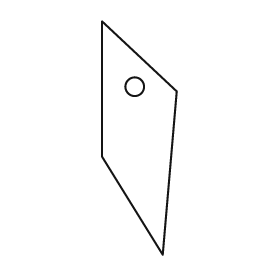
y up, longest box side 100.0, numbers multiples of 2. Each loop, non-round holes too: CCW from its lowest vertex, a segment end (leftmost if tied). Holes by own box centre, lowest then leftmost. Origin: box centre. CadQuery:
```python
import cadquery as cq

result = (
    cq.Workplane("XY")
    .moveTo(10.0, -50.0)
    .lineTo(16.0, 20.0)
    .lineTo(-16.0, 50.0)
    .lineTo(-16.0, -8.0)
    .close()
    .moveTo(-2.0, 22.0)
    .circle(4.0)
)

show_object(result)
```